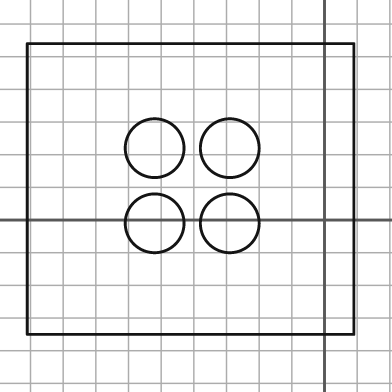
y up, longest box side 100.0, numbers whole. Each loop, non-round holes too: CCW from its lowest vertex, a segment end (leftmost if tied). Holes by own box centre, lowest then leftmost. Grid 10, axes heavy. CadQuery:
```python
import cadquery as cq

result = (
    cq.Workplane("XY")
    .moveTo(-91.0, -35.0)
    .lineTo(9.0, -35.0)
    .lineTo(9.0, 54.0)
    .lineTo(-91.0, 54.0)
    .close()
    .moveTo(-52.0, -1.0)
    .circle(9.0)
    .moveTo(-29.0, -1.0)
    .circle(9.0)
    .moveTo(-52.0, 22.0)
    .circle(9.0)
    .moveTo(-29.0, 22.0)
    .circle(9.0)
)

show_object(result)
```